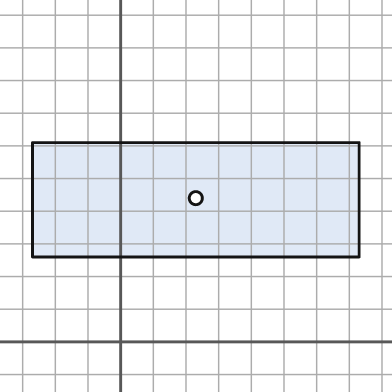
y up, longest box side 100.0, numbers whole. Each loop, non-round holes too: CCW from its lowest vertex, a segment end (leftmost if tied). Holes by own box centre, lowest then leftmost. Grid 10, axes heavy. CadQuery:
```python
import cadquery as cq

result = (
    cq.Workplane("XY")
    .moveTo(-27.0, 26.0)
    .lineTo(73.0, 26.0)
    .lineTo(73.0, 61.0)
    .lineTo(-27.0, 61.0)
    .close()
    .moveTo(23.0, 44.0)
    .circle(2.0)
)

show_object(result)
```